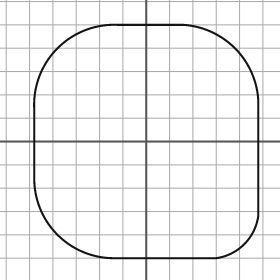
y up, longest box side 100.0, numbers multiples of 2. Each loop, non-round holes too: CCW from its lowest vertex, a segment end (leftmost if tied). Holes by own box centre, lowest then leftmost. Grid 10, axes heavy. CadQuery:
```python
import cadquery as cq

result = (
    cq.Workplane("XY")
    .moveTo(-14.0, -50.0)
    .lineTo(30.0, -50.0)
    .threePointArc((42.0, -44.0), (48.0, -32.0))
    .lineTo(48.0, 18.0)
    .threePointArc((38.0, 40.0), (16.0, 50.0))
    .lineTo(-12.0, 50.0)
    .threePointArc((-38.0, 40.0), (-48.0, 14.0))
    .lineTo(-48.0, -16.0)
    .threePointArc((-38.0, -40.0), (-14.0, -50.0))
    .close()
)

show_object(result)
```